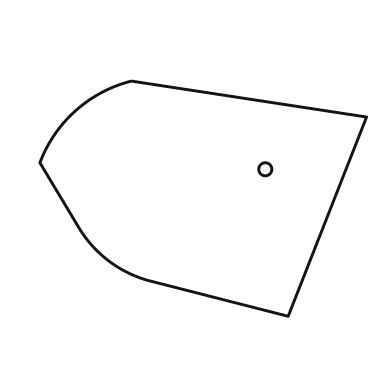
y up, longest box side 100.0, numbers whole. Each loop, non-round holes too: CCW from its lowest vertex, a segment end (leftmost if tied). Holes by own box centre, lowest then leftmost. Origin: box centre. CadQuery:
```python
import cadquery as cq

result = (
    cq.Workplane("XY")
    .moveTo(26.0, -36.0)
    .lineTo(50.0, 25.0)
    .lineTo(-22.0, 36.0)
    .threePointArc((-39.0, 27.0), (-50.0, 11.0))
    .lineTo(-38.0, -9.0)
    .threePointArc((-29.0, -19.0), (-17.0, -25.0))
    .close()
    .moveTo(19.0, 9.0)
    .circle(2.0)
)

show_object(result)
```